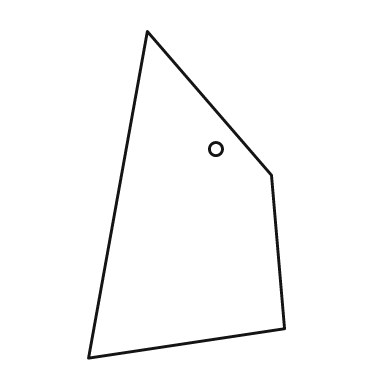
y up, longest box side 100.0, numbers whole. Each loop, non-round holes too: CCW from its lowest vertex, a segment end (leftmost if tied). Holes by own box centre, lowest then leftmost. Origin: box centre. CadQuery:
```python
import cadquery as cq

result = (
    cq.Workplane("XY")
    .moveTo(-30.0, -50.0)
    .lineTo(30.0, -41.0)
    .lineTo(26.0, 6.0)
    .lineTo(-12.0, 50.0)
    .close()
    .moveTo(9.0, 14.0)
    .circle(2.0)
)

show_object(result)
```